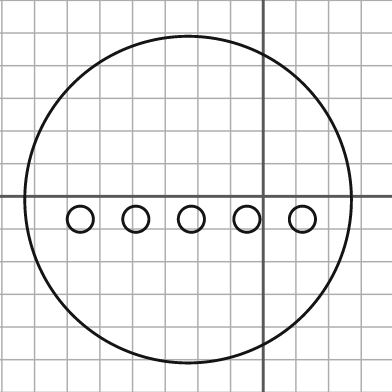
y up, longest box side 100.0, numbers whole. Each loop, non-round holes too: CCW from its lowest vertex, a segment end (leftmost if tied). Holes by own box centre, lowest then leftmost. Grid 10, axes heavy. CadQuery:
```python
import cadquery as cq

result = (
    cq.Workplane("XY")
    .moveTo(-23.0, -1.0)
    .circle(50.0)
    .moveTo(-56.0, -7.0)
    .circle(4.0)
    .moveTo(-39.0, -7.0)
    .circle(4.0)
    .moveTo(-22.0, -7.0)
    .circle(4.0)
    .moveTo(-5.0, -7.0)
    .circle(4.0)
    .moveTo(12.0, -7.0)
    .circle(4.0)
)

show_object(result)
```